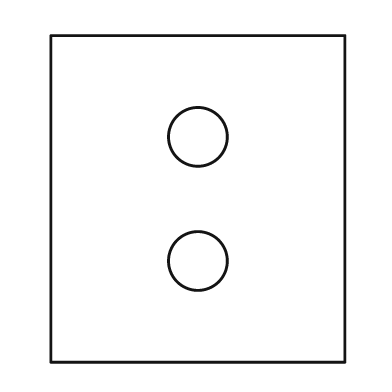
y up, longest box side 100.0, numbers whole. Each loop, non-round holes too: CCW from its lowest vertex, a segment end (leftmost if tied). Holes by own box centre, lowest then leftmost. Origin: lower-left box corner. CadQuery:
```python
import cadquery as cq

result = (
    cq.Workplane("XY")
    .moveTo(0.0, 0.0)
    .lineTo(90.0, 0.0)
    .lineTo(90.0, 100.0)
    .lineTo(0.0, 100.0)
    .close()
    .moveTo(45.0, 31.0)
    .circle(9.0)
    .moveTo(45.0, 69.0)
    .circle(9.0)
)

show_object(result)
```